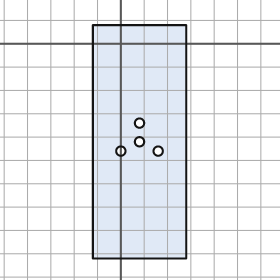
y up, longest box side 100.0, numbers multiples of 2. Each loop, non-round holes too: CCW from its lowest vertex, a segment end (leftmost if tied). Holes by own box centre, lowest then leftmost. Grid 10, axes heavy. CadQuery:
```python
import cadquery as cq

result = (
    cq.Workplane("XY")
    .moveTo(-12.0, -92.0)
    .lineTo(28.0, -92.0)
    .lineTo(28.0, 8.0)
    .lineTo(-12.0, 8.0)
    .close()
    .moveTo(0.0, -46.0)
    .circle(2.0)
    .moveTo(16.0, -46.0)
    .circle(2.0)
    .moveTo(8.0, -42.0)
    .circle(2.0)
    .moveTo(8.0, -34.0)
    .circle(2.0)
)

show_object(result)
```